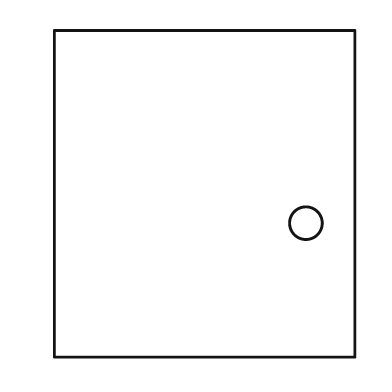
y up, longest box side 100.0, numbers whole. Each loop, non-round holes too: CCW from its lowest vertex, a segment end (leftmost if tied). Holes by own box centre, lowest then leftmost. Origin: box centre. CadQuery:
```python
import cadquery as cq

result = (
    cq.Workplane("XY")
    .moveTo(-46.0, -50.0)
    .lineTo(46.0, -50.0)
    .lineTo(46.0, 50.0)
    .lineTo(-46.0, 50.0)
    .close()
    .moveTo(31.0, -9.0)
    .circle(5.0)
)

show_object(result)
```